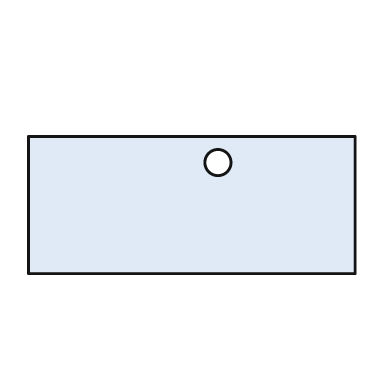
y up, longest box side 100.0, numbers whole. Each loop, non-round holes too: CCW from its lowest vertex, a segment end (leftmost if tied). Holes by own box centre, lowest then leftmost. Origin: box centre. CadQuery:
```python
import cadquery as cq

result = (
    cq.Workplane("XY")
    .moveTo(-50.0, -21.0)
    .lineTo(50.0, -21.0)
    .lineTo(50.0, 21.0)
    .lineTo(-50.0, 21.0)
    .close()
    .moveTo(8.0, 13.0)
    .circle(4.0)
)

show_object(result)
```